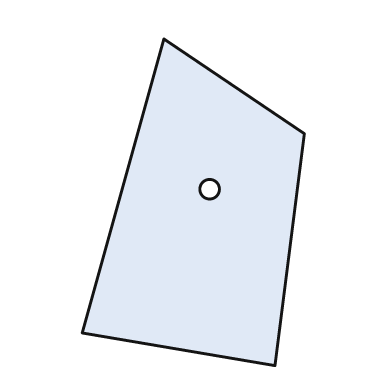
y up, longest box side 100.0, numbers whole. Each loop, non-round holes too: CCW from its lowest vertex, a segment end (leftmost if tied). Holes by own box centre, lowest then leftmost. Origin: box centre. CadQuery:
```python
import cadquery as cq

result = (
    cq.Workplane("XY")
    .moveTo(25.0, -50.0)
    .lineTo(34.0, 21.0)
    .lineTo(-9.0, 50.0)
    .lineTo(-34.0, -40.0)
    .close()
    .moveTo(5.0, 4.0)
    .circle(3.0)
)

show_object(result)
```